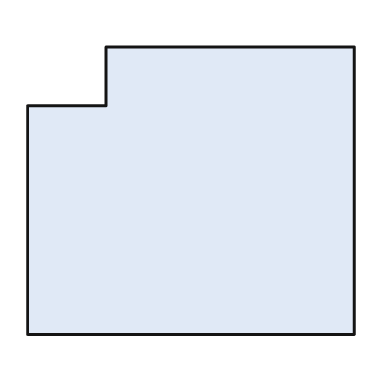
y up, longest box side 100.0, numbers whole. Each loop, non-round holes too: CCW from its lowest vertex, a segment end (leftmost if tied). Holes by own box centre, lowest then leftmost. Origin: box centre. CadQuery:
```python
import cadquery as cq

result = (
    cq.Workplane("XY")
    .moveTo(-50.0, -44.0)
    .lineTo(50.0, -44.0)
    .lineTo(50.0, 44.0)
    .lineTo(-26.0, 44.0)
    .lineTo(-26.0, 26.0)
    .lineTo(-50.0, 26.0)
    .close()
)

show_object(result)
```